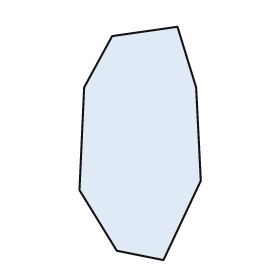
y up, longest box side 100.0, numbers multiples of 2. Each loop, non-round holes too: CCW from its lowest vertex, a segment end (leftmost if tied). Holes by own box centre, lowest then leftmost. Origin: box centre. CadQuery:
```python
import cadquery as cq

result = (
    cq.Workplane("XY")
    .moveTo(10.0, -50.0)
    .lineTo(26.0, -16.0)
    .lineTo(24.0, 24.0)
    .lineTo(16.0, 50.0)
    .lineTo(-12.0, 46.0)
    .lineTo(-24.0, 24.0)
    .lineTo(-26.0, -20.0)
    .lineTo(-10.0, -46.0)
    .close()
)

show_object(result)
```